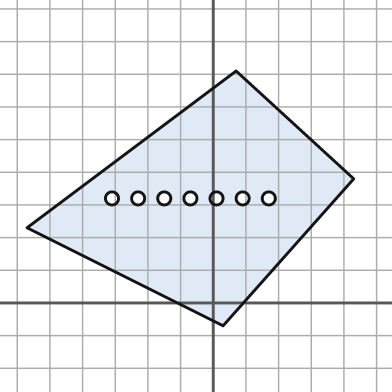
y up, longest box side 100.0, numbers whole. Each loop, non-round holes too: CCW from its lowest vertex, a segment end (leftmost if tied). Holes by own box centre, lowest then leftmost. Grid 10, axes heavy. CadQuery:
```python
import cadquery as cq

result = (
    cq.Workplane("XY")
    .moveTo(3.0, -7.0)
    .lineTo(43.0, 38.0)
    .lineTo(7.0, 71.0)
    .lineTo(-57.0, 23.0)
    .close()
    .moveTo(-31.0, 32.0)
    .circle(2.0)
    .moveTo(-23.0, 32.0)
    .circle(2.0)
    .moveTo(-15.0, 32.0)
    .circle(2.0)
    .moveTo(-7.0, 32.0)
    .circle(2.0)
    .moveTo(1.0, 32.0)
    .circle(2.0)
    .moveTo(9.0, 32.0)
    .circle(2.0)
    .moveTo(17.0, 32.0)
    .circle(2.0)
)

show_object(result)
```